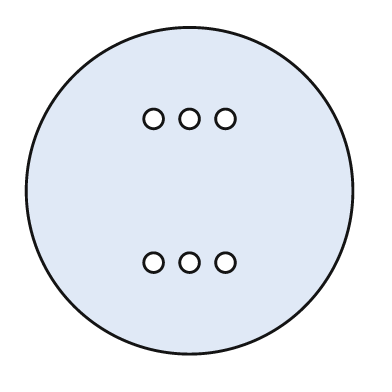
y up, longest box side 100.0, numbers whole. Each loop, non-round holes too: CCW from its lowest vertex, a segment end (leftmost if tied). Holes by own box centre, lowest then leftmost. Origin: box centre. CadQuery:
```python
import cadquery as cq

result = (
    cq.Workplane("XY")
    .moveTo(0.0, 0.0)
    .circle(50.0)
    .moveTo(-11.0, -22.0)
    .circle(3.0)
    .moveTo(0.0, -22.0)
    .circle(3.0)
    .moveTo(11.0, -22.0)
    .circle(3.0)
    .moveTo(-11.0, 22.0)
    .circle(3.0)
    .moveTo(0.0, 22.0)
    .circle(3.0)
    .moveTo(11.0, 22.0)
    .circle(3.0)
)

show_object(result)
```